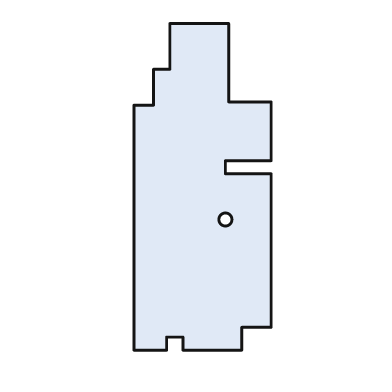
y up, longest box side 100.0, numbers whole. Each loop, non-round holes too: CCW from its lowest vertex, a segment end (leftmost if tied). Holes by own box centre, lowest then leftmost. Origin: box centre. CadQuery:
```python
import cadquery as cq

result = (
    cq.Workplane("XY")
    .moveTo(-21.0, -50.0)
    .lineTo(-11.0, -50.0)
    .lineTo(-11.0, -46.0)
    .lineTo(-6.0, -46.0)
    .lineTo(-6.0, -50.0)
    .lineTo(12.0, -50.0)
    .lineTo(12.0, -43.0)
    .lineTo(21.0, -43.0)
    .lineTo(21.0, 4.0)
    .lineTo(7.0, 4.0)
    .lineTo(7.0, 8.0)
    .lineTo(21.0, 8.0)
    .lineTo(21.0, 26.0)
    .lineTo(8.0, 26.0)
    .lineTo(8.0, 50.0)
    .lineTo(-10.0, 50.0)
    .lineTo(-10.0, 36.0)
    .lineTo(-15.0, 36.0)
    .lineTo(-15.0, 25.0)
    .lineTo(-21.0, 25.0)
    .close()
    .moveTo(7.0, -10.0)
    .circle(2.0)
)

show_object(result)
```